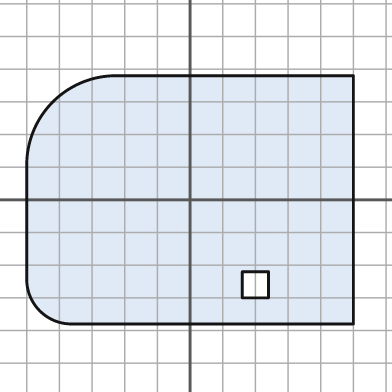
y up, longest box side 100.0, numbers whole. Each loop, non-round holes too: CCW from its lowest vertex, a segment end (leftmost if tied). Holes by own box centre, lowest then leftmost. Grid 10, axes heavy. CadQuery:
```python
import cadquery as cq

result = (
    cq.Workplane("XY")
    .moveTo(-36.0, -38.0)
    .lineTo(50.0, -38.0)
    .lineTo(50.0, 38.0)
    .lineTo(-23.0, 38.0)
    .threePointArc((-42.0, 30.0), (-50.0, 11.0))
    .lineTo(-50.0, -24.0)
    .threePointArc((-46.0, -34.0), (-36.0, -38.0))
    .close()
    .moveTo(16.0, -30.0)
    .lineTo(24.0, -30.0)
    .lineTo(24.0, -22.0)
    .lineTo(16.0, -22.0)
    .close()
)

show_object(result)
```